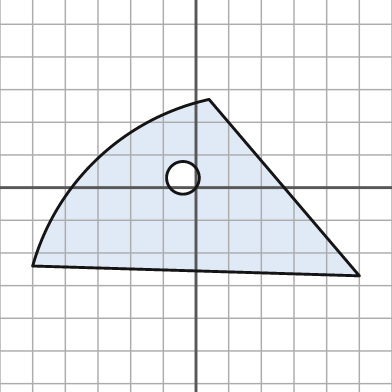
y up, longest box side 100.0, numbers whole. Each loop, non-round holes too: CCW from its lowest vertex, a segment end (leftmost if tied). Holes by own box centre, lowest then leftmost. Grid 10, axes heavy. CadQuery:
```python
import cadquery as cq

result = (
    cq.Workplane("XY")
    .moveTo(50.0, -27.0)
    .lineTo(4.0, 27.0)
    .threePointArc((-30.0, 9.0), (-50.0, -24.0))
    .close()
    .moveTo(-4.0, 3.0)
    .circle(5.0)
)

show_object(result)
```